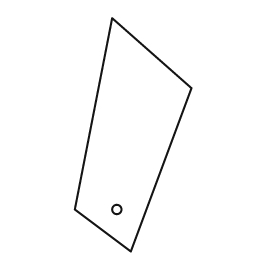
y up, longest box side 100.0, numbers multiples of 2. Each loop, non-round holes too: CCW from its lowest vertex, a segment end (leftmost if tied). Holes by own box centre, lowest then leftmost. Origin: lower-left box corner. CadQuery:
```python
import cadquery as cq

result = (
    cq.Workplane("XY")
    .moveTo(24.0, 0.0)
    .lineTo(50.0, 70.0)
    .lineTo(16.0, 100.0)
    .lineTo(0.0, 18.0)
    .close()
    .moveTo(18.0, 18.0)
    .circle(2.0)
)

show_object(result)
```